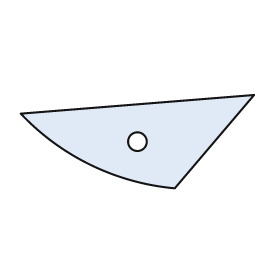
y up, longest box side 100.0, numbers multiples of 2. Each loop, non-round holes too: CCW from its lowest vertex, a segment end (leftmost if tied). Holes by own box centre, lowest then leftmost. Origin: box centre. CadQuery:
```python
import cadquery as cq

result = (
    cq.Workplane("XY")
    .moveTo(16.0, -20.0)
    .lineTo(50.0, 20.0)
    .lineTo(-50.0, 12.0)
    .threePointArc((-20.0, -10.0), (16.0, -20.0))
    .close()
    .moveTo(0.0, 0.0)
    .circle(4.0)
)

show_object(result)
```